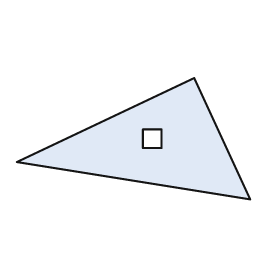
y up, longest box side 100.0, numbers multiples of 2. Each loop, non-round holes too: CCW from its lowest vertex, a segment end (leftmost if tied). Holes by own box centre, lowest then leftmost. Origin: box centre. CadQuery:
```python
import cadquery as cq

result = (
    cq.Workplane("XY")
    .moveTo(50.0, -26.0)
    .lineTo(26.0, 26.0)
    .lineTo(-50.0, -10.0)
    .close()
    .moveTo(4.0, -4.0)
    .lineTo(12.0, -4.0)
    .lineTo(12.0, 4.0)
    .lineTo(4.0, 4.0)
    .close()
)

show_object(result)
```